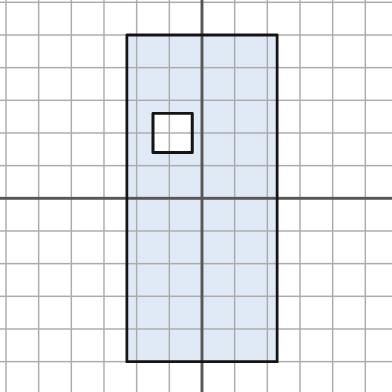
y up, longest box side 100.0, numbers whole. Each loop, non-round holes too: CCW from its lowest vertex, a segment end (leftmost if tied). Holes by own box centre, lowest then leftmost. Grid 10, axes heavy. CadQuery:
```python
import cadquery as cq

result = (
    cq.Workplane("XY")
    .moveTo(-23.0, -50.0)
    .lineTo(23.0, -50.0)
    .lineTo(23.0, 50.0)
    .lineTo(-23.0, 50.0)
    .close()
    .moveTo(-15.0, 14.0)
    .lineTo(-3.0, 14.0)
    .lineTo(-3.0, 26.0)
    .lineTo(-15.0, 26.0)
    .close()
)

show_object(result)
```